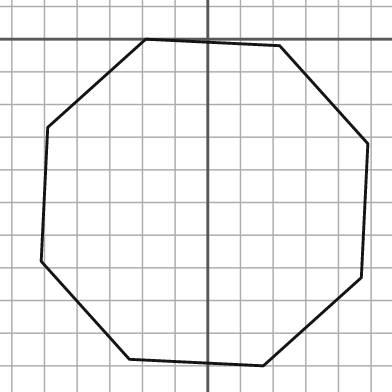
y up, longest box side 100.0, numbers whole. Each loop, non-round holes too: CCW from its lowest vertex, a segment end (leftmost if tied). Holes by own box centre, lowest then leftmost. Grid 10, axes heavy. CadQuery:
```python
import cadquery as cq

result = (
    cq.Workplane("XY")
    .moveTo(17.0, -100.0)
    .lineTo(47.0, -73.0)
    .lineTo(49.0, -32.0)
    .lineTo(22.0, -2.0)
    .lineTo(-19.0, 0.0)
    .lineTo(-49.0, -27.0)
    .lineTo(-51.0, -68.0)
    .lineTo(-24.0, -98.0)
    .close()
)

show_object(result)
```